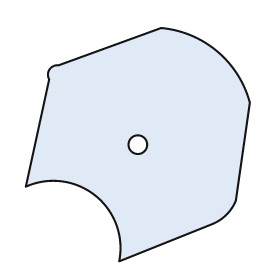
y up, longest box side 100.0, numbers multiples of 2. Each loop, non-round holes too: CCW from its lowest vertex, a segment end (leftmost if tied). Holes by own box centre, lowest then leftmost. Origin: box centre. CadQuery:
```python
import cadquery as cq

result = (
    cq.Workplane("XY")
    .moveTo(-8.0, -50.0)
    .lineTo(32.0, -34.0)
    .threePointArc((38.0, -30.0), (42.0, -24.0))
    .lineTo(48.0, 18.0)
    .threePointArc((34.0, 40.0), (10.0, 50.0))
    .lineTo(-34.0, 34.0)
    .threePointArc((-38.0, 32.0), (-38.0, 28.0))
    .lineTo(-48.0, -18.0)
    .threePointArc((-18.0, -22.0), (-8.0, -50.0))
    .close()
    .moveTo(0.0, 0.0)
    .circle(4.0)
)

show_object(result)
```